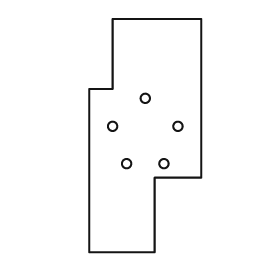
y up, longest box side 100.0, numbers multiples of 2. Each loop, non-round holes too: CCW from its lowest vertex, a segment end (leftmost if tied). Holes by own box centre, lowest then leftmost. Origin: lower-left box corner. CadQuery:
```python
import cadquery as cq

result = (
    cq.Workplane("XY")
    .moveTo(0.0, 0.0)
    .lineTo(28.0, 0.0)
    .lineTo(28.0, 32.0)
    .lineTo(48.0, 32.0)
    .lineTo(48.0, 100.0)
    .lineTo(10.0, 100.0)
    .lineTo(10.0, 70.0)
    .lineTo(0.0, 70.0)
    .close()
    .moveTo(16.0, 38.0)
    .circle(2.0)
    .moveTo(32.0, 38.0)
    .circle(2.0)
    .moveTo(10.0, 54.0)
    .circle(2.0)
    .moveTo(38.0, 54.0)
    .circle(2.0)
    .moveTo(24.0, 66.0)
    .circle(2.0)
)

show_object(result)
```